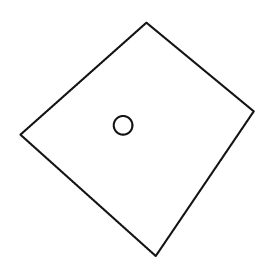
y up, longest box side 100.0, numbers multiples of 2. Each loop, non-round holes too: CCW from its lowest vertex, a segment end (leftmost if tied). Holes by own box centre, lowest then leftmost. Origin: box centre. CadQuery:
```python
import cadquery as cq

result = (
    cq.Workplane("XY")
    .moveTo(8.0, -50.0)
    .lineTo(50.0, 12.0)
    .lineTo(4.0, 50.0)
    .lineTo(-50.0, 2.0)
    .close()
    .moveTo(-6.0, 6.0)
    .circle(4.0)
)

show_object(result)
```